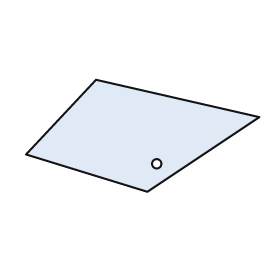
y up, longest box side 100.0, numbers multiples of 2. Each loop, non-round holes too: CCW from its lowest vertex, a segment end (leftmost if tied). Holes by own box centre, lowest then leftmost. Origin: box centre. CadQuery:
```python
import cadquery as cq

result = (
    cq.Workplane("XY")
    .moveTo(2.0, -24.0)
    .lineTo(50.0, 8.0)
    .lineTo(-20.0, 24.0)
    .lineTo(-50.0, -8.0)
    .close()
    .moveTo(6.0, -12.0)
    .circle(2.0)
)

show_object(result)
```